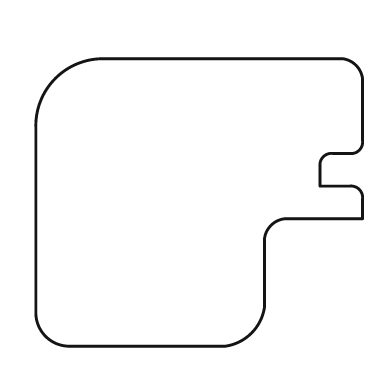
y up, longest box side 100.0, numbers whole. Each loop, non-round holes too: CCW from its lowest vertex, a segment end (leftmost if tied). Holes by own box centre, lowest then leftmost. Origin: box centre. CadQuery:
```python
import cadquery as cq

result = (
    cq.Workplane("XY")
    .moveTo(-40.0, -44.0)
    .lineTo(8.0, -44.0)
    .threePointArc((16.0, -40.0), (20.0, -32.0))
    .lineTo(20.0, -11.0)
    .threePointArc((22.0, -7.0), (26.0, -5.0))
    .lineTo(50.0, -5.0)
    .lineTo(50.0, 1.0)
    .threePointArc((49.0, 4.0), (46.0, 5.0))
    .lineTo(37.0, 5.0)
    .lineTo(37.0, 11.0)
    .threePointArc((38.0, 14.0), (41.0, 15.0))
    .lineTo(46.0, 15.0)
    .threePointArc((49.0, 16.0), (50.0, 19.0))
    .lineTo(50.0, 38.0)
    .threePointArc((48.0, 42.0), (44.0, 44.0))
    .lineTo(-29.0, 44.0)
    .threePointArc((-44.0, 38.0), (-50.0, 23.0))
    .lineTo(-50.0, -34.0)
    .threePointArc((-47.0, -41.0), (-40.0, -44.0))
    .close()
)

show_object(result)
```